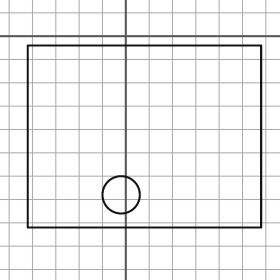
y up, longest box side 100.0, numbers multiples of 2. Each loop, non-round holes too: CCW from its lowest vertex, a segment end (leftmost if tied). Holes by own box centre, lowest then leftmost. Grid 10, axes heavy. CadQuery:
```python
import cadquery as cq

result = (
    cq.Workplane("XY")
    .moveTo(-42.0, -82.0)
    .lineTo(58.0, -82.0)
    .lineTo(58.0, -4.0)
    .lineTo(-42.0, -4.0)
    .close()
    .moveTo(-2.0, -68.0)
    .circle(8.0)
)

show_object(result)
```